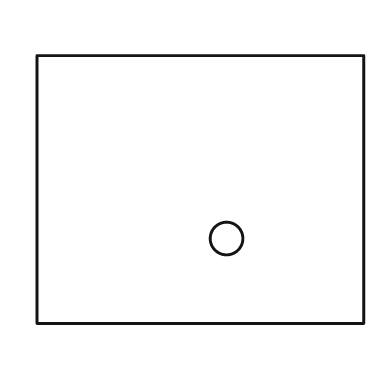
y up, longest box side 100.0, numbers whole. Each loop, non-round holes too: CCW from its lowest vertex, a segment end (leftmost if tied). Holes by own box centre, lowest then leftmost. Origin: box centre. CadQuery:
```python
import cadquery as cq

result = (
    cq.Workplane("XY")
    .moveTo(-50.0, -41.0)
    .lineTo(50.0, -41.0)
    .lineTo(50.0, 41.0)
    .lineTo(-50.0, 41.0)
    .close()
    .moveTo(8.0, -15.0)
    .circle(5.0)
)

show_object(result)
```